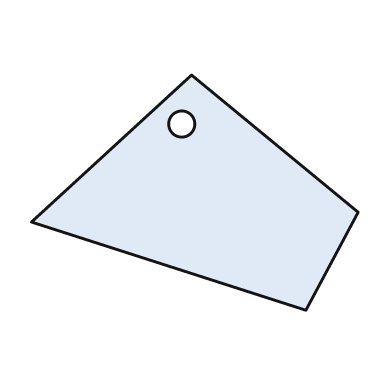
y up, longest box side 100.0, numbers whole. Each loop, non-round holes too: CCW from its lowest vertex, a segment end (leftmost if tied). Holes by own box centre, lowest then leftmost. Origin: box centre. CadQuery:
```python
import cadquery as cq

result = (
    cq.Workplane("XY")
    .moveTo(34.0, -36.0)
    .lineTo(50.0, -6.0)
    .lineTo(-1.0, 36.0)
    .lineTo(-50.0, -9.0)
    .close()
    .moveTo(-4.0, 21.0)
    .circle(4.0)
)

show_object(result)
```